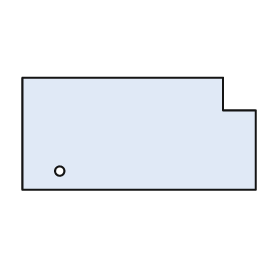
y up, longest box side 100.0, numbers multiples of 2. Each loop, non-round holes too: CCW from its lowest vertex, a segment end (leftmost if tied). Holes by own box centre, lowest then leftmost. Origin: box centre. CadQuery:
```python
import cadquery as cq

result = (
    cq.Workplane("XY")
    .moveTo(-50.0, -24.0)
    .lineTo(50.0, -24.0)
    .lineTo(50.0, 10.0)
    .lineTo(36.0, 10.0)
    .lineTo(36.0, 24.0)
    .lineTo(-50.0, 24.0)
    .close()
    .moveTo(-34.0, -16.0)
    .circle(2.0)
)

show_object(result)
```